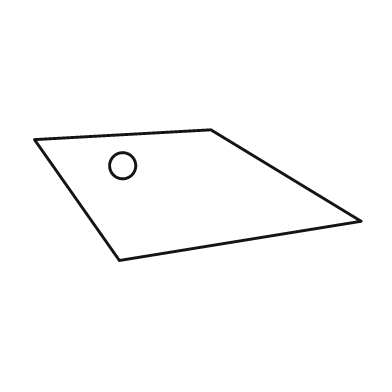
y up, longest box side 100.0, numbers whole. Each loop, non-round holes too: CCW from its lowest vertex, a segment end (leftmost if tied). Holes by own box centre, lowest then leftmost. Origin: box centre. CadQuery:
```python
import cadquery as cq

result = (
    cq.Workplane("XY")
    .moveTo(-24.0, -20.0)
    .lineTo(50.0, -8.0)
    .lineTo(4.0, 20.0)
    .lineTo(-50.0, 17.0)
    .close()
    .moveTo(-23.0, 9.0)
    .circle(4.0)
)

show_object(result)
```